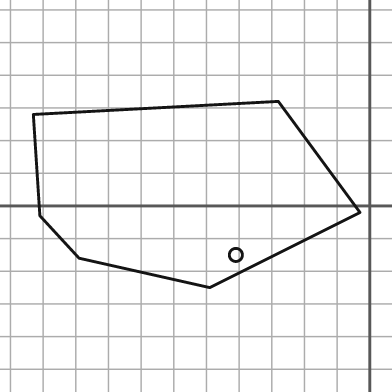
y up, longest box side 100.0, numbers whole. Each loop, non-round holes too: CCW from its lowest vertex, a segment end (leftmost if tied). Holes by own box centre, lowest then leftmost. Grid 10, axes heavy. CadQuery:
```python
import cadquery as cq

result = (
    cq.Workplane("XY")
    .moveTo(-49.0, -25.0)
    .lineTo(-3.0, -2.0)
    .lineTo(-28.0, 32.0)
    .lineTo(-103.0, 28.0)
    .lineTo(-101.0, -3.0)
    .lineTo(-89.0, -16.0)
    .close()
    .moveTo(-41.0, -15.0)
    .circle(2.0)
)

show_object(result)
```